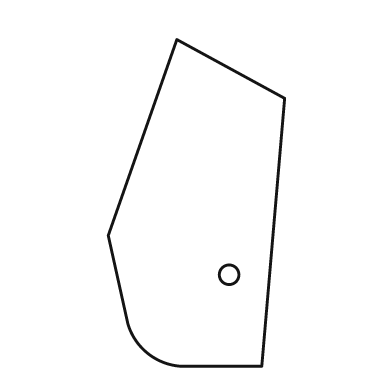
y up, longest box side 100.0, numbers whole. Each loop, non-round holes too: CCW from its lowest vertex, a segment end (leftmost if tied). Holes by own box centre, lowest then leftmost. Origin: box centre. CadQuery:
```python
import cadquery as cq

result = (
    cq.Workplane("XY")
    .moveTo(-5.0, -50.0)
    .lineTo(20.0, -50.0)
    .lineTo(27.0, 32.0)
    .lineTo(-6.0, 50.0)
    .lineTo(-27.0, -10.0)
    .lineTo(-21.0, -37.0)
    .threePointArc((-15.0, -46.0), (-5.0, -50.0))
    .close()
    .moveTo(10.0, -22.0)
    .circle(3.0)
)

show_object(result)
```